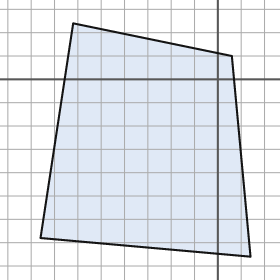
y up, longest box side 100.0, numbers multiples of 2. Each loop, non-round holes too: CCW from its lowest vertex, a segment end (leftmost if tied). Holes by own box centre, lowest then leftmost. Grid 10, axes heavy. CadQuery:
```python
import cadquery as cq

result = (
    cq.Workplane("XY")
    .moveTo(14.0, -76.0)
    .lineTo(6.0, 10.0)
    .lineTo(-62.0, 24.0)
    .lineTo(-76.0, -68.0)
    .close()
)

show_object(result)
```